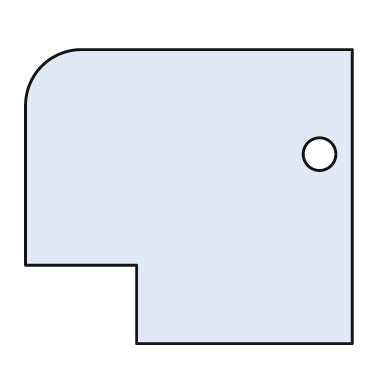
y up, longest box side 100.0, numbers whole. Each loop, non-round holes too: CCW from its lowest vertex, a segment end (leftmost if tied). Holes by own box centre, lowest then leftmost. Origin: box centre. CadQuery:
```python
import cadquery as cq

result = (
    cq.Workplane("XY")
    .moveTo(-16.0, -45.0)
    .lineTo(50.0, -45.0)
    .lineTo(50.0, 45.0)
    .lineTo(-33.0, 45.0)
    .threePointArc((-45.0, 40.0), (-50.0, 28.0))
    .lineTo(-50.0, -21.0)
    .lineTo(-16.0, -21.0)
    .close()
    .moveTo(40.0, 13.0)
    .circle(5.0)
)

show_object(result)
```